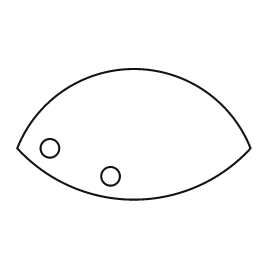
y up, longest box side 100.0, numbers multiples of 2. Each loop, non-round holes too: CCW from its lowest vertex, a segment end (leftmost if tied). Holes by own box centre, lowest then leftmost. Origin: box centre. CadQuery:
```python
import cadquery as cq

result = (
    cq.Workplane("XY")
    .moveTo(-50.0, -6.0)
    .threePointArc((0.0, -28.0), (50.0, -6.0))
    .threePointArc((0.0, 28.0), (-50.0, -6.0))
    .close()
    .moveTo(-10.0, -18.0)
    .circle(4.0)
    .moveTo(-36.0, -6.0)
    .circle(4.0)
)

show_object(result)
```